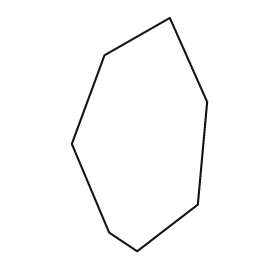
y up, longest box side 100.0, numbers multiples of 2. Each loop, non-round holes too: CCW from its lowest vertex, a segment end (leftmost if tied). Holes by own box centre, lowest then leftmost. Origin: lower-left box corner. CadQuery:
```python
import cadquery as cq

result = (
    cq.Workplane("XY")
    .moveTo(28.0, 0.0)
    .lineTo(54.0, 20.0)
    .lineTo(58.0, 64.0)
    .lineTo(42.0, 100.0)
    .lineTo(14.0, 84.0)
    .lineTo(0.0, 46.0)
    .lineTo(16.0, 8.0)
    .close()
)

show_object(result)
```